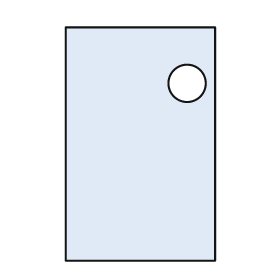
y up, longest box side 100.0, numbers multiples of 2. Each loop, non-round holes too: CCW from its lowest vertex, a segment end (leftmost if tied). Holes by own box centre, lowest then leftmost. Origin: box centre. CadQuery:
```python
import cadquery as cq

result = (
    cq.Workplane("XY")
    .moveTo(-32.0, -50.0)
    .lineTo(32.0, -50.0)
    .lineTo(32.0, 50.0)
    .lineTo(-32.0, 50.0)
    .close()
    .moveTo(20.0, 26.0)
    .circle(8.0)
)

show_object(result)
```